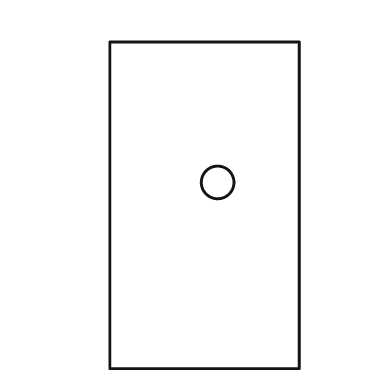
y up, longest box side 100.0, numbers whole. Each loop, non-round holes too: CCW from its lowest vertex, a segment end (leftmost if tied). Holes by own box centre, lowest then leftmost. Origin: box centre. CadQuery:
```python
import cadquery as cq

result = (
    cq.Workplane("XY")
    .moveTo(-29.0, -50.0)
    .lineTo(29.0, -50.0)
    .lineTo(29.0, 50.0)
    .lineTo(-29.0, 50.0)
    .close()
    .moveTo(4.0, 7.0)
    .circle(5.0)
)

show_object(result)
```